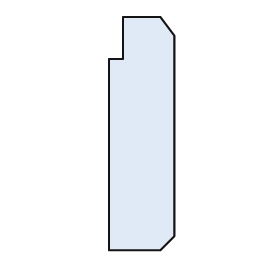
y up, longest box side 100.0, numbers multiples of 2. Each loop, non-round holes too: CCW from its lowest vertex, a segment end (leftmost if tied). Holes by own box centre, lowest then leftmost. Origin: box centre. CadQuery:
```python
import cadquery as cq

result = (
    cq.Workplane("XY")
    .moveTo(-14.0, -50.0)
    .lineTo(8.0, -50.0)
    .lineTo(14.0, -44.0)
    .lineTo(14.0, 42.0)
    .lineTo(8.0, 50.0)
    .lineTo(-8.0, 50.0)
    .lineTo(-8.0, 32.0)
    .lineTo(-14.0, 32.0)
    .close()
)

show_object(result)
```